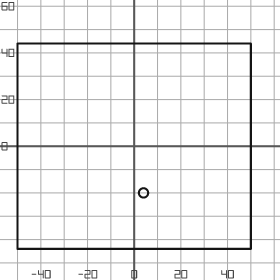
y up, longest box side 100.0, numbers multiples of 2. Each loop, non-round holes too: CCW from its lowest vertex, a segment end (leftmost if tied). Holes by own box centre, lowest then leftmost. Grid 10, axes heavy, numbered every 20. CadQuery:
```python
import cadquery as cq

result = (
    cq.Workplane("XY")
    .moveTo(-50.0, -44.0)
    .lineTo(50.0, -44.0)
    .lineTo(50.0, 44.0)
    .lineTo(-50.0, 44.0)
    .close()
    .moveTo(4.0, -20.0)
    .circle(2.0)
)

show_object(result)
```